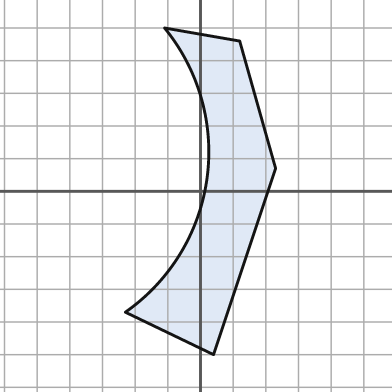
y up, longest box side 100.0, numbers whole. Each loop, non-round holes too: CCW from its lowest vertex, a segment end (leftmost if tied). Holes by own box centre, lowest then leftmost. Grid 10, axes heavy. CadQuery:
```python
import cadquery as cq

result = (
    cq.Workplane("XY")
    .moveTo(4.0, -50.0)
    .lineTo(23.0, 7.0)
    .lineTo(12.0, 46.0)
    .lineTo(-11.0, 50.0)
    .threePointArc((2.0, 4.0), (-23.0, -37.0))
    .close()
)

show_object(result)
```